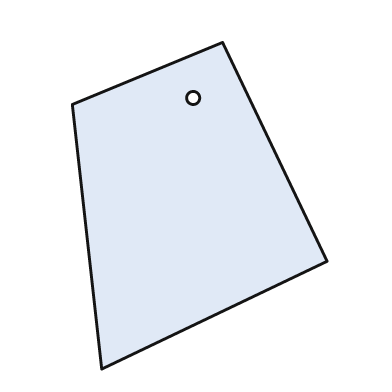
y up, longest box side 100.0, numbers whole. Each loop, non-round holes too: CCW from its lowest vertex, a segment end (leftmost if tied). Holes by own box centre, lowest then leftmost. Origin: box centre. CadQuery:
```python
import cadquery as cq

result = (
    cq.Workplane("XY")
    .moveTo(-30.0, -50.0)
    .lineTo(39.0, -17.0)
    .lineTo(7.0, 50.0)
    .lineTo(-39.0, 31.0)
    .close()
    .moveTo(-2.0, 33.0)
    .circle(2.0)
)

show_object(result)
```